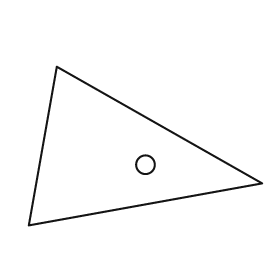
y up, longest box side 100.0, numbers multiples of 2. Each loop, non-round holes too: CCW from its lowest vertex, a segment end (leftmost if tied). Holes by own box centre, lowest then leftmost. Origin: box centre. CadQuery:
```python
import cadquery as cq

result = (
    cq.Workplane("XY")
    .moveTo(-50.0, -34.0)
    .lineTo(50.0, -16.0)
    .lineTo(-38.0, 34.0)
    .close()
    .moveTo(0.0, -8.0)
    .circle(4.0)
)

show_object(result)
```